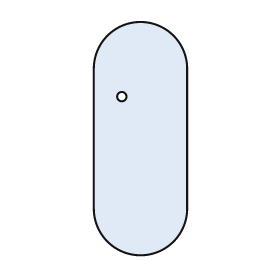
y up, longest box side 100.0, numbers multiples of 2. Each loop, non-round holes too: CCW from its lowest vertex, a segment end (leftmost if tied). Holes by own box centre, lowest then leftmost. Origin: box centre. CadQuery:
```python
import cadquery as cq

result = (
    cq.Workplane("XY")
    .moveTo(-20.0, -30.0)
    .threePointArc((0.0, -50.0), (20.0, -30.0))
    .lineTo(20.0, 30.0)
    .threePointArc((0.0, 50.0), (-20.0, 30.0))
    .close()
    .moveTo(-8.0, 18.0)
    .circle(2.0)
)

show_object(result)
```